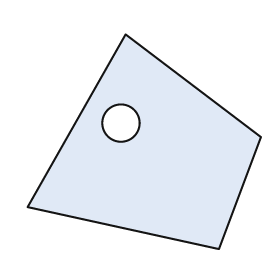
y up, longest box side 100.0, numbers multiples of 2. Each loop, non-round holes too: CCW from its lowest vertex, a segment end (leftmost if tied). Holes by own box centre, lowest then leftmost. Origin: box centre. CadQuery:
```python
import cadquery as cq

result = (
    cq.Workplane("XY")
    .moveTo(32.0, -46.0)
    .lineTo(50.0, 2.0)
    .lineTo(-8.0, 46.0)
    .lineTo(-50.0, -28.0)
    .close()
    .moveTo(-10.0, 8.0)
    .circle(8.0)
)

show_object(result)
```